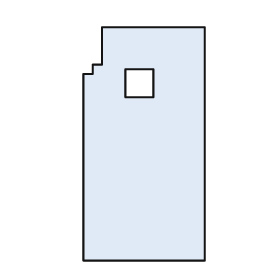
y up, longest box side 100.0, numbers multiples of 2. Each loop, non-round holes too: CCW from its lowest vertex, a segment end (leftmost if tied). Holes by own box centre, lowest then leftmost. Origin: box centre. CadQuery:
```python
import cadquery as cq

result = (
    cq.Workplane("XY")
    .moveTo(-26.0, -50.0)
    .lineTo(26.0, -50.0)
    .lineTo(26.0, 50.0)
    .lineTo(-18.0, 50.0)
    .lineTo(-18.0, 34.0)
    .lineTo(-22.0, 34.0)
    .lineTo(-22.0, 30.0)
    .lineTo(-26.0, 30.0)
    .close()
    .moveTo(-8.0, 20.0)
    .lineTo(4.0, 20.0)
    .lineTo(4.0, 32.0)
    .lineTo(-8.0, 32.0)
    .close()
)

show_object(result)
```